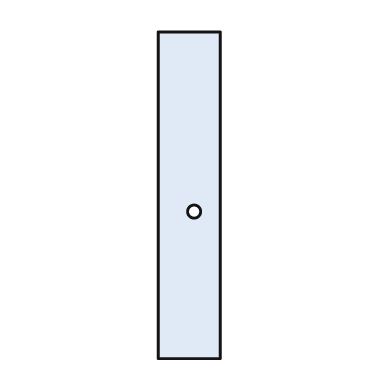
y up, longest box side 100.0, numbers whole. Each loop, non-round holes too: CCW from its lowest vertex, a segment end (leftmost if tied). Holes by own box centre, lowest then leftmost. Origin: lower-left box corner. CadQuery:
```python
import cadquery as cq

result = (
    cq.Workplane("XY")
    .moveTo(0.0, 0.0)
    .lineTo(19.0, 0.0)
    .lineTo(19.0, 100.0)
    .lineTo(0.0, 100.0)
    .close()
    .moveTo(11.0, 45.0)
    .circle(2.0)
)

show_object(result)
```